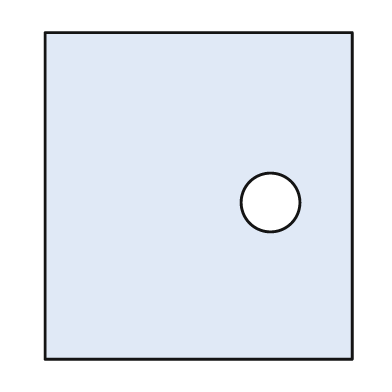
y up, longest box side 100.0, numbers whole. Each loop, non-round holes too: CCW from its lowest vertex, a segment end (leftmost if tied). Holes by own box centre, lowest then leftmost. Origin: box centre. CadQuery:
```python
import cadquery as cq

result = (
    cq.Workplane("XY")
    .moveTo(-47.0, -50.0)
    .lineTo(47.0, -50.0)
    .lineTo(47.0, 50.0)
    .lineTo(-47.0, 50.0)
    .close()
    .moveTo(22.0, -2.0)
    .circle(9.0)
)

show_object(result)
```